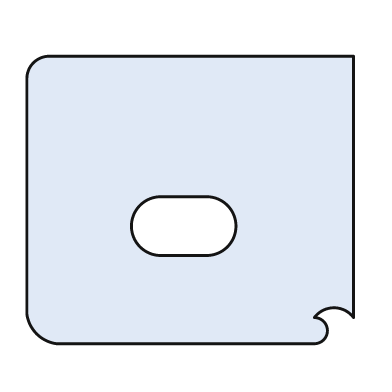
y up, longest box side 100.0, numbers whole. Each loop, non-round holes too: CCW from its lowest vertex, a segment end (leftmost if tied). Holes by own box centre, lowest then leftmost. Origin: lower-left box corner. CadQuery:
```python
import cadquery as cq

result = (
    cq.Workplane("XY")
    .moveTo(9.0, 0.0)
    .lineTo(88.0, 0.0)
    .threePointArc((92.0, 4.0), (88.0, 8.0))
    .threePointArc((94.0, 11.0), (100.0, 8.0))
    .lineTo(100.0, 88.0)
    .lineTo(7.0, 88.0)
    .threePointArc((2.0, 86.0), (0.0, 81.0))
    .lineTo(0.0, 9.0)
    .threePointArc((3.0, 3.0), (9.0, 0.0))
    .close()
    .moveTo(41.0, 27.0)
    .lineTo(55.0, 27.0)
    .threePointArc((64.0, 36.0), (55.0, 45.0))
    .lineTo(41.0, 45.0)
    .threePointArc((32.0, 36.0), (41.0, 27.0))
    .close()
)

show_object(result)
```